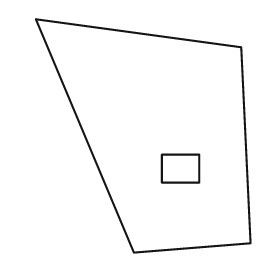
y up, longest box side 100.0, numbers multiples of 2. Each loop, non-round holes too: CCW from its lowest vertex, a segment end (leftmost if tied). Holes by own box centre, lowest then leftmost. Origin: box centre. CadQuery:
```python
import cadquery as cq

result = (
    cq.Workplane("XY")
    .moveTo(-4.0, -50.0)
    .lineTo(46.0, -46.0)
    .lineTo(42.0, 38.0)
    .lineTo(-46.0, 50.0)
    .close()
    .moveTo(8.0, -20.0)
    .lineTo(24.0, -20.0)
    .lineTo(24.0, -8.0)
    .lineTo(8.0, -8.0)
    .close()
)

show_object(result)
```